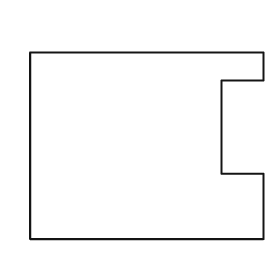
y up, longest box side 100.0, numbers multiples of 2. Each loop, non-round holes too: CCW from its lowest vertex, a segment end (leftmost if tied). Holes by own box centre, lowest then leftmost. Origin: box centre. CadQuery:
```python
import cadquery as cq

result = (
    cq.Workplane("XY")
    .moveTo(-50.0, -40.0)
    .lineTo(50.0, -40.0)
    .lineTo(50.0, -12.0)
    .lineTo(32.0, -12.0)
    .lineTo(32.0, 28.0)
    .lineTo(50.0, 28.0)
    .lineTo(50.0, 40.0)
    .lineTo(-50.0, 40.0)
    .close()
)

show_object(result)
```